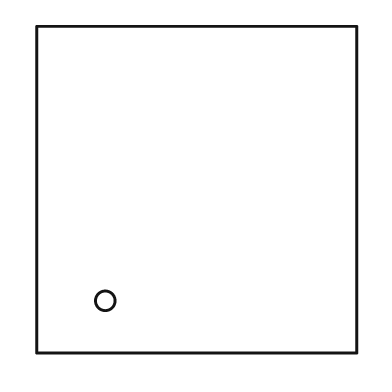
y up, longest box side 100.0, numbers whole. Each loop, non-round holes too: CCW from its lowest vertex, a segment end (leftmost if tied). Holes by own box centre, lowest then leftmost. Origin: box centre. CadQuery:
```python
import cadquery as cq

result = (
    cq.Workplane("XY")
    .moveTo(-49.0, -50.0)
    .lineTo(49.0, -50.0)
    .lineTo(49.0, 50.0)
    .lineTo(-49.0, 50.0)
    .close()
    .moveTo(-28.0, -34.0)
    .circle(3.0)
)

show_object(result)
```